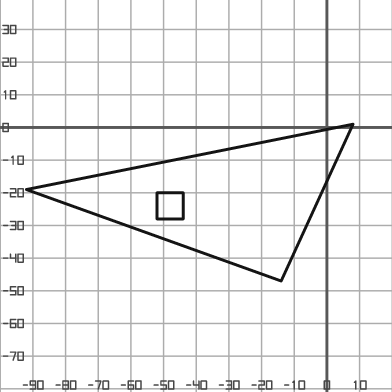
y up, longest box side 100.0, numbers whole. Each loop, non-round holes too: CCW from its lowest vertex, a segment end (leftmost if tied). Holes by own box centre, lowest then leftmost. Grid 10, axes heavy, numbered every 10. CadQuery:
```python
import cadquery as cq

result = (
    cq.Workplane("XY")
    .moveTo(-14.0, -47.0)
    .lineTo(8.0, 1.0)
    .lineTo(-92.0, -19.0)
    .close()
    .moveTo(-52.0, -28.0)
    .lineTo(-44.0, -28.0)
    .lineTo(-44.0, -20.0)
    .lineTo(-52.0, -20.0)
    .close()
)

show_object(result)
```